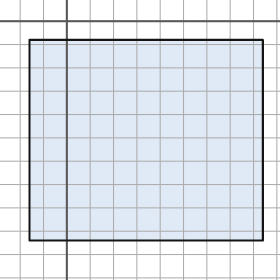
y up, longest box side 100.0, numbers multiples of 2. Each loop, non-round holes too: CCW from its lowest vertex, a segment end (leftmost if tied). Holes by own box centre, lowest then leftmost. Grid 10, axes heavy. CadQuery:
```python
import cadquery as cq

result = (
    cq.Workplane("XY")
    .moveTo(-16.0, -94.0)
    .lineTo(84.0, -94.0)
    .lineTo(84.0, -8.0)
    .lineTo(-16.0, -8.0)
    .close()
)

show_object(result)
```